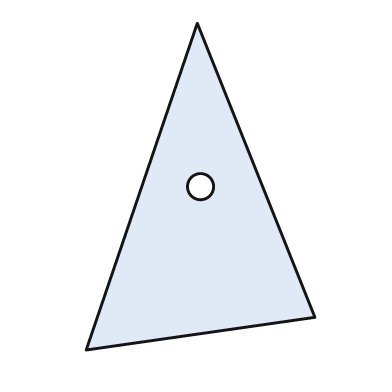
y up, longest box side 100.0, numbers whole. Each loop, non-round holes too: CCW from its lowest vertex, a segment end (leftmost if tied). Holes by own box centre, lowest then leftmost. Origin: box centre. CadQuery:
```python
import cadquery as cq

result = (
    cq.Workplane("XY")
    .moveTo(-35.0, -50.0)
    .lineTo(35.0, -40.0)
    .lineTo(-1.0, 50.0)
    .close()
    .moveTo(0.0, 0.0)
    .circle(4.0)
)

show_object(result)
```